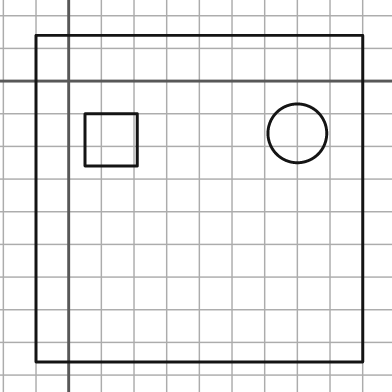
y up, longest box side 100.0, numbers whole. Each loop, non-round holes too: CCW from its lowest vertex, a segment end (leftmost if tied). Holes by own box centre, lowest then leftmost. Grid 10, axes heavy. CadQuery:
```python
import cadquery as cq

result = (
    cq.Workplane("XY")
    .moveTo(-10.0, -86.0)
    .lineTo(90.0, -86.0)
    .lineTo(90.0, 14.0)
    .lineTo(-10.0, 14.0)
    .close()
    .moveTo(5.0, -26.0)
    .lineTo(21.0, -26.0)
    .lineTo(21.0, -10.0)
    .lineTo(5.0, -10.0)
    .close()
    .moveTo(70.0, -16.0)
    .circle(9.0)
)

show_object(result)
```